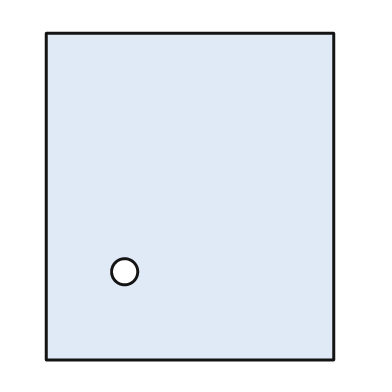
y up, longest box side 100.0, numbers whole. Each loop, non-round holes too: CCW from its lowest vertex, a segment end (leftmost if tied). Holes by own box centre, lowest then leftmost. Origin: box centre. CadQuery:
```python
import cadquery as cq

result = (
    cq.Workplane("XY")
    .moveTo(-44.0, -50.0)
    .lineTo(44.0, -50.0)
    .lineTo(44.0, 50.0)
    .lineTo(-44.0, 50.0)
    .close()
    .moveTo(-20.0, -23.0)
    .circle(4.0)
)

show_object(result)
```